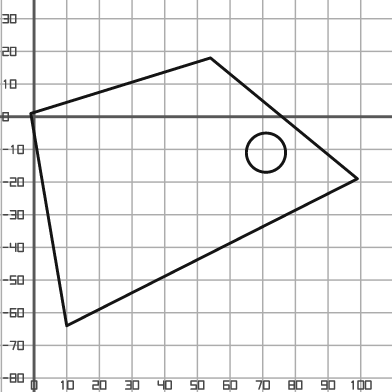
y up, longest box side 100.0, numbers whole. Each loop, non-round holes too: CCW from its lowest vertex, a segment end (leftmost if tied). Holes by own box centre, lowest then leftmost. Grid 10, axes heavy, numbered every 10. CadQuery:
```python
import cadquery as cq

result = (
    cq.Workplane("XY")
    .moveTo(10.0, -64.0)
    .lineTo(99.0, -19.0)
    .lineTo(54.0, 18.0)
    .lineTo(-1.0, 1.0)
    .close()
    .moveTo(71.0, -11.0)
    .circle(6.0)
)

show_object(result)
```